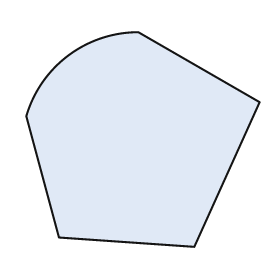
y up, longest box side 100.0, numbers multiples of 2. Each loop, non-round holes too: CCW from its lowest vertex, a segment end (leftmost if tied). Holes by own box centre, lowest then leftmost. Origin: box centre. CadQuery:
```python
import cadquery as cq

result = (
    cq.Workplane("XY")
    .moveTo(22.0, -46.0)
    .lineTo(50.0, 16.0)
    .lineTo(-2.0, 46.0)
    .threePointArc((-32.0, 36.0), (-50.0, 10.0))
    .lineTo(-36.0, -42.0)
    .close()
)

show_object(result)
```